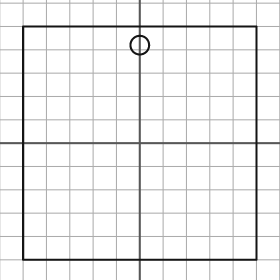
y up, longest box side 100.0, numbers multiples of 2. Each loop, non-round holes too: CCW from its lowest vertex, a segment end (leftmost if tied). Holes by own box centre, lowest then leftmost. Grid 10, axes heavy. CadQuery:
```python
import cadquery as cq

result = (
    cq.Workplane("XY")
    .moveTo(-50.0, -50.0)
    .lineTo(50.0, -50.0)
    .lineTo(50.0, 50.0)
    .lineTo(-50.0, 50.0)
    .close()
    .moveTo(0.0, 42.0)
    .circle(4.0)
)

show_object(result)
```